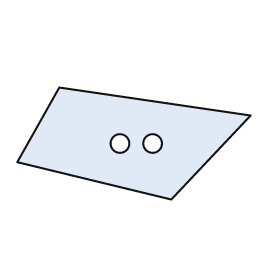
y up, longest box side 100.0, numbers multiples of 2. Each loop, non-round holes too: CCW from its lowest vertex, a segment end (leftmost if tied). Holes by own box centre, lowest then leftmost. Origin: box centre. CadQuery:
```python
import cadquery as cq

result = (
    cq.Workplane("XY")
    .moveTo(16.0, -24.0)
    .lineTo(50.0, 12.0)
    .lineTo(-32.0, 24.0)
    .lineTo(-50.0, -8.0)
    .close()
    .moveTo(-6.0, 0.0)
    .circle(4.0)
    .moveTo(8.0, 0.0)
    .circle(4.0)
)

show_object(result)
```